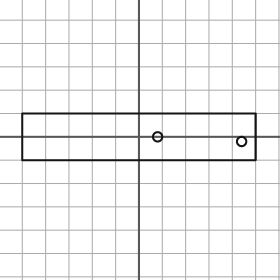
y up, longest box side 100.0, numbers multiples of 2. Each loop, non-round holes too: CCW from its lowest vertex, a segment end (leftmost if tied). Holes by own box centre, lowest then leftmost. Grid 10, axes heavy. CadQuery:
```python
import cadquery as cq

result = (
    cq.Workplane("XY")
    .moveTo(-50.0, -10.0)
    .lineTo(50.0, -10.0)
    .lineTo(50.0, 10.0)
    .lineTo(-50.0, 10.0)
    .close()
    .moveTo(44.0, -2.0)
    .circle(2.0)
    .moveTo(8.0, 0.0)
    .circle(2.0)
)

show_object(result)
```